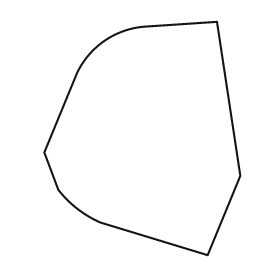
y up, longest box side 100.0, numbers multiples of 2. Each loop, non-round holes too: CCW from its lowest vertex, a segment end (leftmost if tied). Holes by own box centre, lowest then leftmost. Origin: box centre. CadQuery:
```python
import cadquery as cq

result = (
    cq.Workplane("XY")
    .moveTo(28.0, -50.0)
    .lineTo(42.0, -16.0)
    .lineTo(32.0, 50.0)
    .lineTo(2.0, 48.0)
    .threePointArc((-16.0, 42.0), (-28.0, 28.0))
    .lineTo(-42.0, -6.0)
    .lineTo(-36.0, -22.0)
    .threePointArc((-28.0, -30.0), (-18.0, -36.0))
    .close()
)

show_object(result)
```